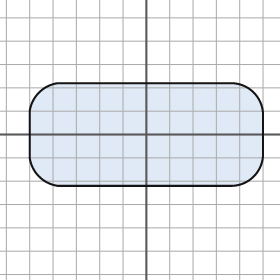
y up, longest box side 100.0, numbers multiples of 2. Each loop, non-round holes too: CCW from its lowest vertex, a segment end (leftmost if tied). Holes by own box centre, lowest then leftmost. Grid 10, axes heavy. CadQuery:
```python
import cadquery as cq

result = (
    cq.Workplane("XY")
    .moveTo(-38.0, -22.0)
    .lineTo(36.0, -22.0)
    .threePointArc((46.0, -18.0), (50.0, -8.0))
    .lineTo(50.0, 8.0)
    .threePointArc((46.0, 18.0), (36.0, 22.0))
    .lineTo(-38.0, 22.0)
    .threePointArc((-46.0, 18.0), (-50.0, 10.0))
    .lineTo(-50.0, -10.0)
    .threePointArc((-46.0, -18.0), (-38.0, -22.0))
    .close()
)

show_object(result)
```